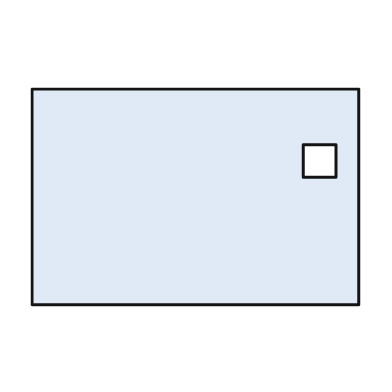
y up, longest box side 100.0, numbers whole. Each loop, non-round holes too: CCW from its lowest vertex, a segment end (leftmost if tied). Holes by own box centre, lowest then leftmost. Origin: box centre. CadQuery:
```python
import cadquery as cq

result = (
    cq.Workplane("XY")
    .moveTo(-50.0, -33.0)
    .lineTo(50.0, -33.0)
    .lineTo(50.0, 33.0)
    .lineTo(-50.0, 33.0)
    .close()
    .moveTo(33.0, 6.0)
    .lineTo(43.0, 6.0)
    .lineTo(43.0, 16.0)
    .lineTo(33.0, 16.0)
    .close()
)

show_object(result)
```